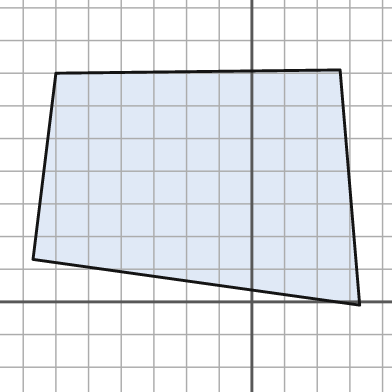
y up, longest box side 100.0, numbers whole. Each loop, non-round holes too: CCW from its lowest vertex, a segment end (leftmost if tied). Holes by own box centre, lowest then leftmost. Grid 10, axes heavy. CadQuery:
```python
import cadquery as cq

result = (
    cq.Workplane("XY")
    .moveTo(33.0, -1.0)
    .lineTo(27.0, 71.0)
    .lineTo(-60.0, 70.0)
    .lineTo(-67.0, 13.0)
    .close()
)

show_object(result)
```